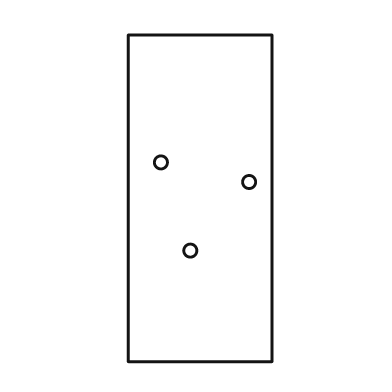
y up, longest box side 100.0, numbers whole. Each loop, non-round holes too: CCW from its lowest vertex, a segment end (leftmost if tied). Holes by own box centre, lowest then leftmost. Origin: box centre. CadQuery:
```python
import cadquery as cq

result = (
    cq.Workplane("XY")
    .moveTo(-22.0, -50.0)
    .lineTo(22.0, -50.0)
    .lineTo(22.0, 50.0)
    .lineTo(-22.0, 50.0)
    .close()
    .moveTo(-3.0, -16.0)
    .circle(2.0)
    .moveTo(15.0, 5.0)
    .circle(2.0)
    .moveTo(-12.0, 11.0)
    .circle(2.0)
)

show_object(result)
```